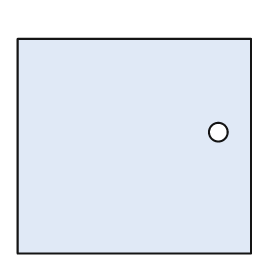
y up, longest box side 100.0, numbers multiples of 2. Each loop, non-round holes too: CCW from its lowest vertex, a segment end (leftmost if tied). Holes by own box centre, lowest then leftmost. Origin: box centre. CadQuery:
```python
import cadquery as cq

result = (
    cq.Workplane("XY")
    .moveTo(-50.0, -46.0)
    .lineTo(50.0, -46.0)
    .lineTo(50.0, 46.0)
    .lineTo(-50.0, 46.0)
    .close()
    .moveTo(36.0, 6.0)
    .circle(4.0)
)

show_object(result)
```